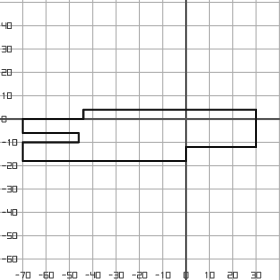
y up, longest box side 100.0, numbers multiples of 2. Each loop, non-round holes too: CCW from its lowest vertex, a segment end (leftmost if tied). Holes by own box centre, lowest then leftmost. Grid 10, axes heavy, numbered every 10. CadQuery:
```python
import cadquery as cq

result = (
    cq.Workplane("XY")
    .moveTo(-70.0, -18.0)
    .lineTo(0.0, -18.0)
    .lineTo(0.0, -12.0)
    .lineTo(30.0, -12.0)
    .lineTo(30.0, 4.0)
    .lineTo(-44.0, 4.0)
    .lineTo(-44.0, 0.0)
    .lineTo(-70.0, 0.0)
    .lineTo(-70.0, -6.0)
    .lineTo(-46.0, -6.0)
    .lineTo(-46.0, -10.0)
    .lineTo(-70.0, -10.0)
    .close()
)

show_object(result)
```